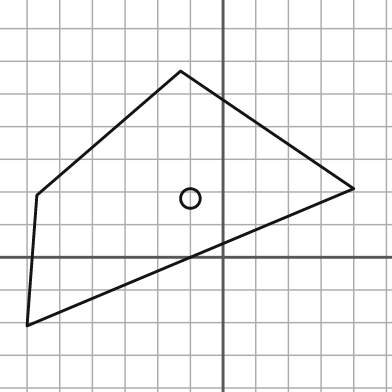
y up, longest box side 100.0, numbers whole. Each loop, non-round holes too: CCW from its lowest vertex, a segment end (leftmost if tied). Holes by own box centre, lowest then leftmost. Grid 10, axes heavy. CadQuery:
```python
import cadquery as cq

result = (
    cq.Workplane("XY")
    .moveTo(-60.0, -21.0)
    .lineTo(40.0, 21.0)
    .lineTo(-13.0, 57.0)
    .lineTo(-57.0, 19.0)
    .close()
    .moveTo(-10.0, 18.0)
    .circle(3.0)
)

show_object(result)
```